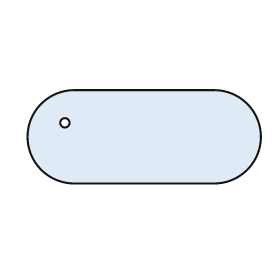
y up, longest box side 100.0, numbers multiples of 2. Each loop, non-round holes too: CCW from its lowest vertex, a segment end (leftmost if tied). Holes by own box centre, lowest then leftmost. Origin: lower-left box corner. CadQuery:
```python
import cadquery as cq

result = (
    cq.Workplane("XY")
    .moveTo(20.0, 0.0)
    .lineTo(80.0, 0.0)
    .threePointArc((100.0, 20.0), (80.0, 40.0))
    .lineTo(20.0, 40.0)
    .threePointArc((0.0, 20.0), (20.0, 0.0))
    .close()
    .moveTo(16.0, 26.0)
    .circle(2.0)
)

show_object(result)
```